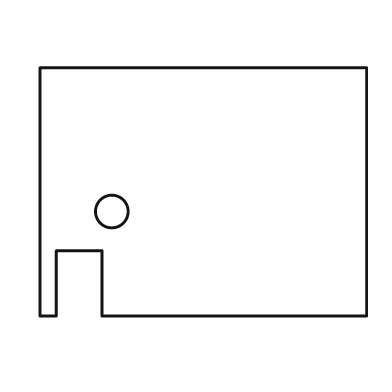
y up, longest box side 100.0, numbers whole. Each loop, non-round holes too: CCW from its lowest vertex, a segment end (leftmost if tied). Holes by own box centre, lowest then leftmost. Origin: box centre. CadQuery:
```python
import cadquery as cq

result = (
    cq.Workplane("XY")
    .moveTo(-50.0, -38.0)
    .lineTo(-45.0, -38.0)
    .lineTo(-45.0, -18.0)
    .lineTo(-31.0, -18.0)
    .lineTo(-31.0, -38.0)
    .lineTo(50.0, -38.0)
    .lineTo(50.0, 38.0)
    .lineTo(-50.0, 38.0)
    .close()
    .moveTo(-28.0, -6.0)
    .circle(5.0)
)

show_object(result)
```